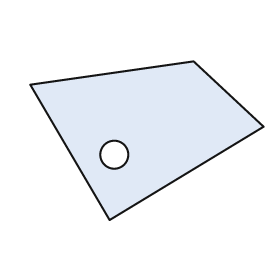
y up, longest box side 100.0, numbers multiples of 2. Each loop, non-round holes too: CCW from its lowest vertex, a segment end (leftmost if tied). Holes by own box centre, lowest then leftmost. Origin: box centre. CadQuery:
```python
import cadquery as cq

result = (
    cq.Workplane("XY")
    .moveTo(-16.0, -34.0)
    .lineTo(50.0, 6.0)
    .lineTo(20.0, 34.0)
    .lineTo(-50.0, 24.0)
    .close()
    .moveTo(-14.0, -6.0)
    .circle(6.0)
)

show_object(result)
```